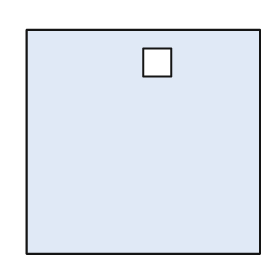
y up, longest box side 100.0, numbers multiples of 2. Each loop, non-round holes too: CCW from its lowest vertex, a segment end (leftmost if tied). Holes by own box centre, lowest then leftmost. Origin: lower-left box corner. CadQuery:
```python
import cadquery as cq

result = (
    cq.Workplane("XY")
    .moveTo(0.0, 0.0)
    .lineTo(100.0, 0.0)
    .lineTo(100.0, 96.0)
    .lineTo(0.0, 96.0)
    .close()
    .moveTo(50.0, 76.0)
    .lineTo(62.0, 76.0)
    .lineTo(62.0, 88.0)
    .lineTo(50.0, 88.0)
    .close()
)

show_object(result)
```